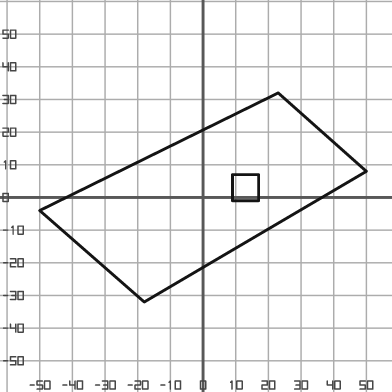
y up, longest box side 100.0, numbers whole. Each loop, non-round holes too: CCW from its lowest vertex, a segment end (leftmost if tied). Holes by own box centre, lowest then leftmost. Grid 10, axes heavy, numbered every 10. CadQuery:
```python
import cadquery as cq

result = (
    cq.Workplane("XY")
    .moveTo(-18.0, -32.0)
    .lineTo(50.0, 8.0)
    .lineTo(23.0, 32.0)
    .lineTo(-50.0, -4.0)
    .close()
    .moveTo(9.0, -1.0)
    .lineTo(17.0, -1.0)
    .lineTo(17.0, 7.0)
    .lineTo(9.0, 7.0)
    .close()
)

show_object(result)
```